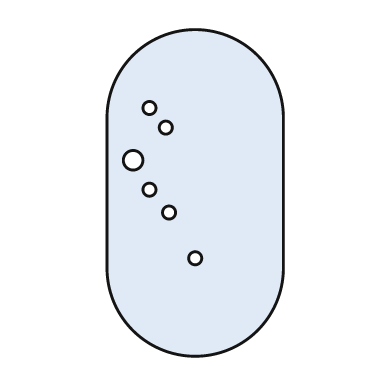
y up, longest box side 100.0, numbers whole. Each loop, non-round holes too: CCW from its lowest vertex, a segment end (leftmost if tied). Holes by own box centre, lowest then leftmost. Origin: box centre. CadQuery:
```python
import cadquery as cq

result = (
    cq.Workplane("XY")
    .moveTo(-27.0, -23.0)
    .threePointArc((0.0, -50.0), (27.0, -23.0))
    .lineTo(27.0, 23.0)
    .threePointArc((0.0, 50.0), (-27.0, 23.0))
    .close()
    .moveTo(0.0, -20.0)
    .circle(2.0)
    .moveTo(-8.0, -6.0)
    .circle(2.0)
    .moveTo(-14.0, 1.0)
    .circle(2.0)
    .moveTo(-19.0, 10.0)
    .circle(3.0)
    .moveTo(-9.0, 20.0)
    .circle(2.0)
    .moveTo(-14.0, 26.0)
    .circle(2.0)
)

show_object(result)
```